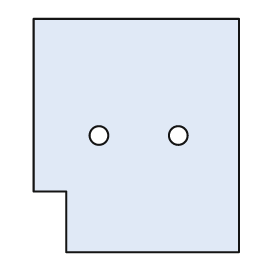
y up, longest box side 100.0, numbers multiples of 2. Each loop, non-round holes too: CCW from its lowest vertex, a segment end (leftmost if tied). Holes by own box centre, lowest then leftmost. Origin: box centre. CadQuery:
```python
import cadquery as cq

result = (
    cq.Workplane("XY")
    .moveTo(-30.0, -50.0)
    .lineTo(44.0, -50.0)
    .lineTo(44.0, 50.0)
    .lineTo(-44.0, 50.0)
    .lineTo(-44.0, -24.0)
    .lineTo(-30.0, -24.0)
    .close()
    .moveTo(-16.0, 0.0)
    .circle(4.0)
    .moveTo(18.0, 0.0)
    .circle(4.0)
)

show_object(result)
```